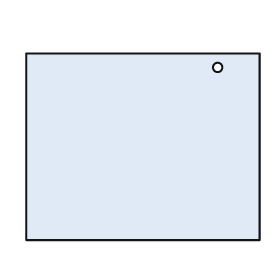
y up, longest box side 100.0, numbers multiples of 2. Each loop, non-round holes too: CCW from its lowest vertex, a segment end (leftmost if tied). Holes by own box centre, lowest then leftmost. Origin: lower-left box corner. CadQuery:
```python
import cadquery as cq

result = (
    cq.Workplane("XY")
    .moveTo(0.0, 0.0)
    .lineTo(100.0, 0.0)
    .lineTo(100.0, 80.0)
    .lineTo(0.0, 80.0)
    .close()
    .moveTo(82.0, 74.0)
    .circle(2.0)
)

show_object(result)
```